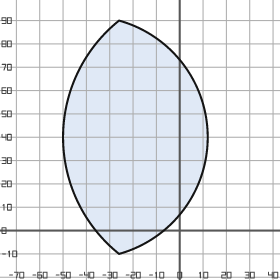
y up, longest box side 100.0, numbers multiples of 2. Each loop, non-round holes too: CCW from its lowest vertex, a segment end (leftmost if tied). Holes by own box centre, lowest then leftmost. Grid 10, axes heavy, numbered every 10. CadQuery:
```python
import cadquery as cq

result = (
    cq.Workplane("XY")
    .moveTo(-26.0, -10.0)
    .threePointArc((12.0, 40.0), (-26.0, 90.0))
    .threePointArc((-50.0, 40.0), (-26.0, -10.0))
    .close()
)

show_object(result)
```